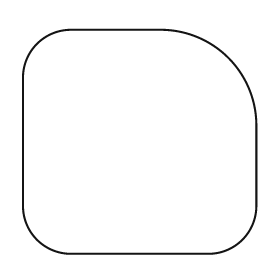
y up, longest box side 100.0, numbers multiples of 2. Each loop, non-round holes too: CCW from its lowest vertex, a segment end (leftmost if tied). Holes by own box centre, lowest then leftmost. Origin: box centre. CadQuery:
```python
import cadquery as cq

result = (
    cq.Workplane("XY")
    .moveTo(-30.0, -48.0)
    .lineTo(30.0, -48.0)
    .threePointArc((44.0, -42.0), (50.0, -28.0))
    .lineTo(50.0, 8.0)
    .threePointArc((38.0, 36.0), (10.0, 48.0))
    .lineTo(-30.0, 48.0)
    .threePointArc((-44.0, 42.0), (-50.0, 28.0))
    .lineTo(-50.0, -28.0)
    .threePointArc((-44.0, -42.0), (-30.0, -48.0))
    .close()
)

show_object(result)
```